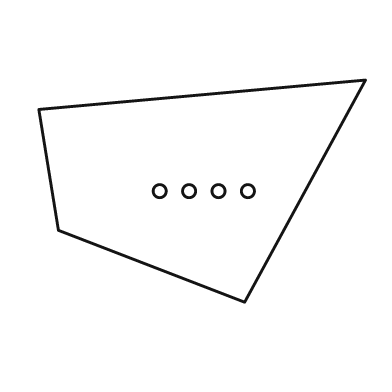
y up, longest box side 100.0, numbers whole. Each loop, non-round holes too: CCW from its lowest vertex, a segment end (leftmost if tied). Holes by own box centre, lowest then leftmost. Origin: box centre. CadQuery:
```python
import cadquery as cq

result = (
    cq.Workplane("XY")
    .moveTo(13.0, -34.0)
    .lineTo(50.0, 34.0)
    .lineTo(-50.0, 25.0)
    .lineTo(-44.0, -12.0)
    .close()
    .moveTo(-13.0, 0.0)
    .circle(2.0)
    .moveTo(-4.0, 0.0)
    .circle(2.0)
    .moveTo(5.0, 0.0)
    .circle(2.0)
    .moveTo(14.0, 0.0)
    .circle(2.0)
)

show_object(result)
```